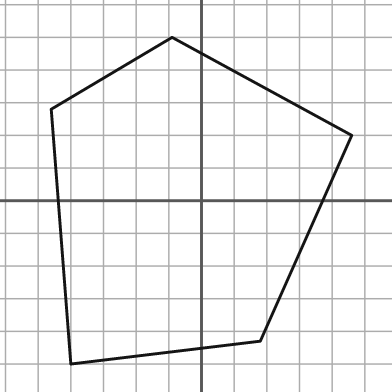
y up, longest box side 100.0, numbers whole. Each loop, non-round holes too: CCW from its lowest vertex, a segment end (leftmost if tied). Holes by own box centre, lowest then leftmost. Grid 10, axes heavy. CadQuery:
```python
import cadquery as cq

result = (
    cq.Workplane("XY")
    .moveTo(-40.0, -50.0)
    .lineTo(18.0, -43.0)
    .lineTo(46.0, 20.0)
    .lineTo(-9.0, 50.0)
    .lineTo(-46.0, 28.0)
    .close()
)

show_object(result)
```